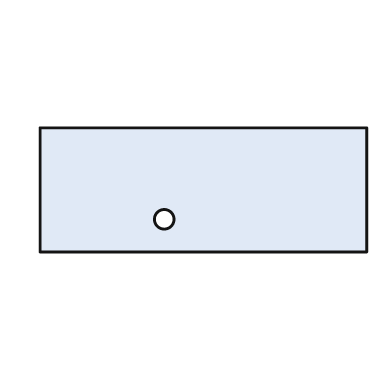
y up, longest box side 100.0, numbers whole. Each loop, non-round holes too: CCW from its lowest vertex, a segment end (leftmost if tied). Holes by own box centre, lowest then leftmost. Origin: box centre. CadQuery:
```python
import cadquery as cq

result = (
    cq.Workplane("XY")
    .moveTo(-50.0, -19.0)
    .lineTo(50.0, -19.0)
    .lineTo(50.0, 19.0)
    .lineTo(-50.0, 19.0)
    .close()
    .moveTo(-12.0, -9.0)
    .circle(3.0)
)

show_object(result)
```